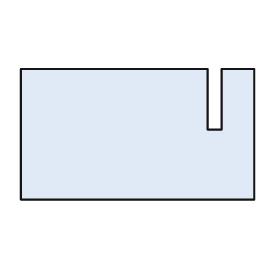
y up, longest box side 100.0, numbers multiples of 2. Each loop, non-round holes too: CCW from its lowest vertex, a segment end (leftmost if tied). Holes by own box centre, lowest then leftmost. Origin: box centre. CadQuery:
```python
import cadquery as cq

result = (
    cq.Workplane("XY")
    .moveTo(-50.0, -28.0)
    .lineTo(50.0, -28.0)
    .lineTo(50.0, 28.0)
    .lineTo(36.0, 28.0)
    .lineTo(36.0, 2.0)
    .lineTo(30.0, 2.0)
    .lineTo(30.0, 28.0)
    .lineTo(-50.0, 28.0)
    .close()
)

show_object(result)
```